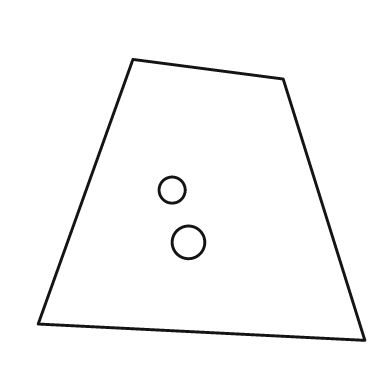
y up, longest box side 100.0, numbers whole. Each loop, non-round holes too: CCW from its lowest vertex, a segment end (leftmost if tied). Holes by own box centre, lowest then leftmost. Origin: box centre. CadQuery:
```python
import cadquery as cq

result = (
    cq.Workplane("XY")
    .moveTo(50.0, -43.0)
    .lineTo(25.0, 37.0)
    .lineTo(-21.0, 43.0)
    .lineTo(-50.0, -38.0)
    .close()
    .moveTo(-4.0, -13.0)
    .circle(5.0)
    .moveTo(-9.0, 3.0)
    .circle(4.0)
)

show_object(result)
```